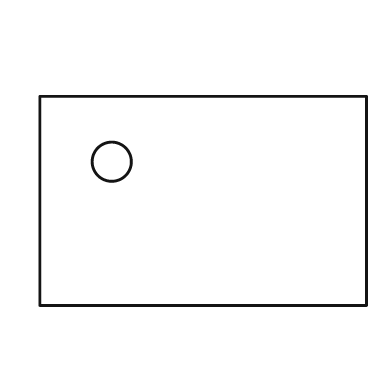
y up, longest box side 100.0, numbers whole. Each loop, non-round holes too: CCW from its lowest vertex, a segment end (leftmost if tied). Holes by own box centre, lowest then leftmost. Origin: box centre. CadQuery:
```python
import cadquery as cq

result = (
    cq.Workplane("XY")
    .moveTo(-50.0, -32.0)
    .lineTo(50.0, -32.0)
    .lineTo(50.0, 32.0)
    .lineTo(-50.0, 32.0)
    .close()
    .moveTo(-28.0, 12.0)
    .circle(6.0)
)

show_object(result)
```